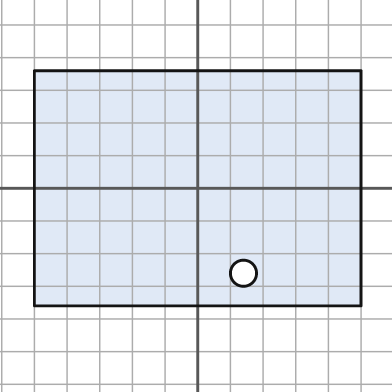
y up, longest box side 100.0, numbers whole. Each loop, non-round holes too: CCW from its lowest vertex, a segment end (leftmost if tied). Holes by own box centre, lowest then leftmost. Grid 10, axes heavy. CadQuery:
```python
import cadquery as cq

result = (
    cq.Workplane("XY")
    .moveTo(-50.0, -36.0)
    .lineTo(50.0, -36.0)
    .lineTo(50.0, 36.0)
    .lineTo(-50.0, 36.0)
    .close()
    .moveTo(14.0, -26.0)
    .circle(4.0)
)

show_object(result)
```